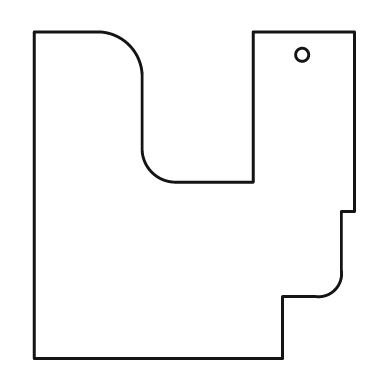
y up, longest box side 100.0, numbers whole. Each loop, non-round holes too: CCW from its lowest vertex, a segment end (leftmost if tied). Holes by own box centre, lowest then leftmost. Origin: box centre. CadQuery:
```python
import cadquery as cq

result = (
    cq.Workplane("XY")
    .moveTo(-49.0, -50.0)
    .lineTo(27.0, -50.0)
    .lineTo(27.0, -31.0)
    .lineTo(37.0, -31.0)
    .threePointArc((43.0, -29.0), (45.0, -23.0))
    .lineTo(45.0, -5.0)
    .lineTo(49.0, -5.0)
    .lineTo(49.0, 50.0)
    .lineTo(18.0, 50.0)
    .lineTo(18.0, 4.0)
    .lineTo(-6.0, 4.0)
    .threePointArc((-13.0, 7.0), (-16.0, 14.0))
    .lineTo(-16.0, 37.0)
    .threePointArc((-20.0, 46.0), (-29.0, 50.0))
    .lineTo(-49.0, 50.0)
    .close()
    .moveTo(33.0, 43.0)
    .circle(2.0)
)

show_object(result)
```